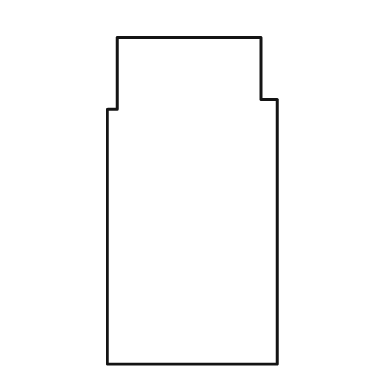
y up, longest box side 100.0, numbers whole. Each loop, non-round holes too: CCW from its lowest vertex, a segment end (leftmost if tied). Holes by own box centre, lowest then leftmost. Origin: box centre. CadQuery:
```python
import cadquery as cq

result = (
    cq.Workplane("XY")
    .moveTo(-26.0, -50.0)
    .lineTo(26.0, -50.0)
    .lineTo(26.0, 31.0)
    .lineTo(21.0, 31.0)
    .lineTo(21.0, 50.0)
    .lineTo(-23.0, 50.0)
    .lineTo(-23.0, 28.0)
    .lineTo(-26.0, 28.0)
    .close()
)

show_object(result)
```